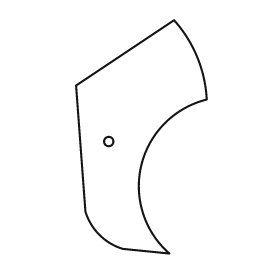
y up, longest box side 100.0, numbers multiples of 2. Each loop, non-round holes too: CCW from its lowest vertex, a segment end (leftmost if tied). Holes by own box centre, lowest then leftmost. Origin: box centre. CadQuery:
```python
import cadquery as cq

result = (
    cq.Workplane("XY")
    .moveTo(12.0, -50.0)
    .threePointArc((0.0, -12.0), (28.0, 16.0))
    .threePointArc((24.0, 34.0), (14.0, 50.0))
    .lineTo(-28.0, 22.0)
    .lineTo(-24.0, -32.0)
    .threePointArc((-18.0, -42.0), (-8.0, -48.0))
    .close()
    .moveTo(-14.0, -2.0)
    .circle(2.0)
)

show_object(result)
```